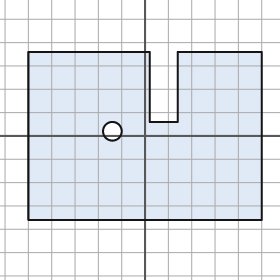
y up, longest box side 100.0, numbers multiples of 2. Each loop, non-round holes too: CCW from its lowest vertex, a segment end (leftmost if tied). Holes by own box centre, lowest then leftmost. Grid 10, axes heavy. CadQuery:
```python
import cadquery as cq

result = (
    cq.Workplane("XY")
    .moveTo(-50.0, -36.0)
    .lineTo(50.0, -36.0)
    .lineTo(50.0, 36.0)
    .lineTo(14.0, 36.0)
    .lineTo(14.0, 6.0)
    .lineTo(2.0, 6.0)
    .lineTo(2.0, 36.0)
    .lineTo(-50.0, 36.0)
    .close()
    .moveTo(-14.0, 2.0)
    .circle(4.0)
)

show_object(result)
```